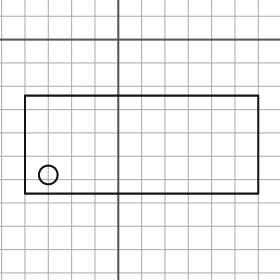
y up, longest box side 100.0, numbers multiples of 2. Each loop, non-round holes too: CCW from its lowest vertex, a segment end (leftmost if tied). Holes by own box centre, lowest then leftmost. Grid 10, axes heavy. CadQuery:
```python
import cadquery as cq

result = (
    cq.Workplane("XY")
    .moveTo(-40.0, -66.0)
    .lineTo(60.0, -66.0)
    .lineTo(60.0, -24.0)
    .lineTo(-40.0, -24.0)
    .close()
    .moveTo(-30.0, -58.0)
    .circle(4.0)
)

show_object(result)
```